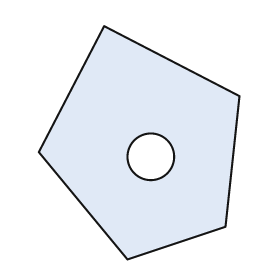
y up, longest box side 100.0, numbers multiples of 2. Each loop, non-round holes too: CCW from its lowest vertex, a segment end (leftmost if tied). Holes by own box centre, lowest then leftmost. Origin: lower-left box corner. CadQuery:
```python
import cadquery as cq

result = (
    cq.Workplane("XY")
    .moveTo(38.0, 0.0)
    .lineTo(80.0, 14.0)
    .lineTo(86.0, 70.0)
    .lineTo(28.0, 100.0)
    .lineTo(0.0, 46.0)
    .close()
    .moveTo(48.0, 44.0)
    .circle(10.0)
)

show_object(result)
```